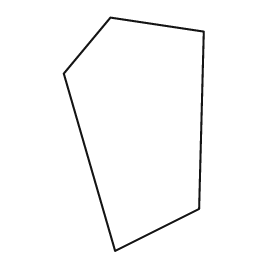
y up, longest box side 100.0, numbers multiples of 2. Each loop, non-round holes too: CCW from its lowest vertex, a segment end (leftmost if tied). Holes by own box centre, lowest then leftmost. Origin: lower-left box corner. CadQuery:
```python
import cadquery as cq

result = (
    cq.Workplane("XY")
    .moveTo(22.0, 0.0)
    .lineTo(58.0, 18.0)
    .lineTo(60.0, 94.0)
    .lineTo(20.0, 100.0)
    .lineTo(0.0, 76.0)
    .close()
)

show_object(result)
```